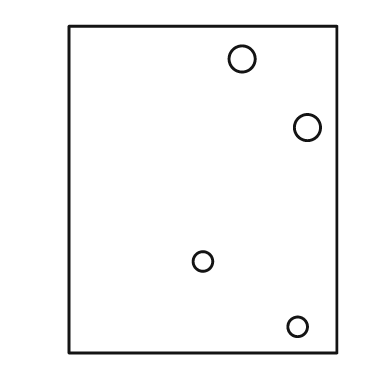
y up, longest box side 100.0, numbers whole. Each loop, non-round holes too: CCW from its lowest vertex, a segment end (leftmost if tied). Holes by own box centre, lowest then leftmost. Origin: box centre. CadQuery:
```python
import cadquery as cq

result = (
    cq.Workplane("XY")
    .moveTo(-41.0, -50.0)
    .lineTo(41.0, -50.0)
    .lineTo(41.0, 50.0)
    .lineTo(-41.0, 50.0)
    .close()
    .moveTo(29.0, -42.0)
    .circle(3.0)
    .moveTo(0.0, -22.0)
    .circle(3.0)
    .moveTo(32.0, 19.0)
    .circle(4.0)
    .moveTo(12.0, 40.0)
    .circle(4.0)
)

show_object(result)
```